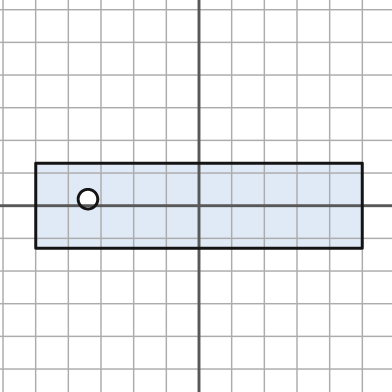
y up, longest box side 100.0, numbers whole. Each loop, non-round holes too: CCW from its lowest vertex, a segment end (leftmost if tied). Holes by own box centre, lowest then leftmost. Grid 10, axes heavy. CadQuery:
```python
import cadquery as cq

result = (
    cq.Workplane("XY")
    .moveTo(-50.0, -13.0)
    .lineTo(50.0, -13.0)
    .lineTo(50.0, 13.0)
    .lineTo(-50.0, 13.0)
    .close()
    .moveTo(-34.0, 2.0)
    .circle(3.0)
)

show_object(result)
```